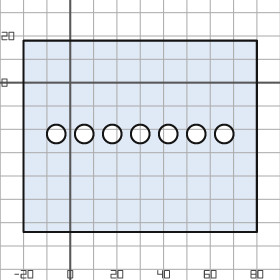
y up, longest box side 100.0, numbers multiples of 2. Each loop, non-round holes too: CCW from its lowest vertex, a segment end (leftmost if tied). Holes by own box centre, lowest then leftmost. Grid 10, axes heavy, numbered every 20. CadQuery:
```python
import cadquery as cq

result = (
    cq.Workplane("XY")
    .moveTo(-20.0, -64.0)
    .lineTo(80.0, -64.0)
    .lineTo(80.0, 18.0)
    .lineTo(-20.0, 18.0)
    .close()
    .moveTo(-6.0, -22.0)
    .circle(4.0)
    .moveTo(6.0, -22.0)
    .circle(4.0)
    .moveTo(18.0, -22.0)
    .circle(4.0)
    .moveTo(30.0, -22.0)
    .circle(4.0)
    .moveTo(42.0, -22.0)
    .circle(4.0)
    .moveTo(54.0, -22.0)
    .circle(4.0)
    .moveTo(66.0, -22.0)
    .circle(4.0)
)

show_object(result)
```